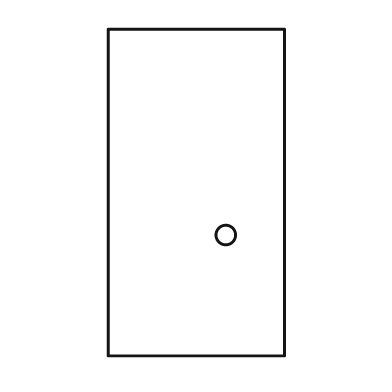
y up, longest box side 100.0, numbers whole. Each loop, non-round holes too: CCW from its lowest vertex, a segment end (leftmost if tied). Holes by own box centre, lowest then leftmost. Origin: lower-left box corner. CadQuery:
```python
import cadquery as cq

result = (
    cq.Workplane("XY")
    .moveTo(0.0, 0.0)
    .lineTo(54.0, 0.0)
    .lineTo(54.0, 100.0)
    .lineTo(0.0, 100.0)
    .close()
    .moveTo(36.0, 37.0)
    .circle(3.0)
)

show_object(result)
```